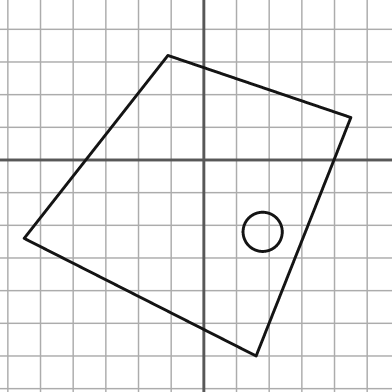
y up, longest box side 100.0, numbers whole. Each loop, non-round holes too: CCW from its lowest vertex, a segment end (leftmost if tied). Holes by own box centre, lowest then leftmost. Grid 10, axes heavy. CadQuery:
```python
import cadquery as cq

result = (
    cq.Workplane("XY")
    .moveTo(16.0, -60.0)
    .lineTo(45.0, 13.0)
    .lineTo(-11.0, 32.0)
    .lineTo(-55.0, -24.0)
    .close()
    .moveTo(18.0, -22.0)
    .circle(6.0)
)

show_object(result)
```